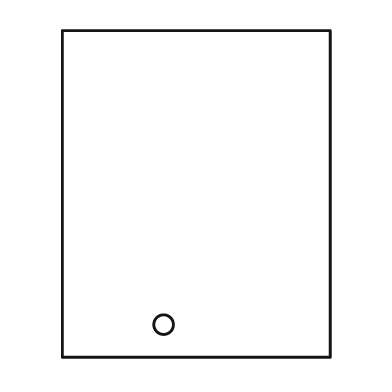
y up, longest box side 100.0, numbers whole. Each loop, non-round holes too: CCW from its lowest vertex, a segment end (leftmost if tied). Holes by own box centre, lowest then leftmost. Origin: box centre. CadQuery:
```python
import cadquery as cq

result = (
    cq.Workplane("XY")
    .moveTo(-41.0, -50.0)
    .lineTo(41.0, -50.0)
    .lineTo(41.0, 50.0)
    .lineTo(-41.0, 50.0)
    .close()
    .moveTo(-10.0, -40.0)
    .circle(3.0)
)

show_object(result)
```